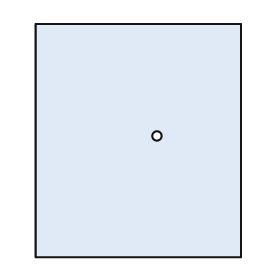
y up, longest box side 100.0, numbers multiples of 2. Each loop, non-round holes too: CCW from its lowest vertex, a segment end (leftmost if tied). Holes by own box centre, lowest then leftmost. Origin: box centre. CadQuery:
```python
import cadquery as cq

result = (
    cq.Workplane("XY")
    .moveTo(-44.0, -50.0)
    .lineTo(44.0, -50.0)
    .lineTo(44.0, 50.0)
    .lineTo(-44.0, 50.0)
    .close()
    .moveTo(8.0, 2.0)
    .circle(2.0)
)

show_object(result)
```